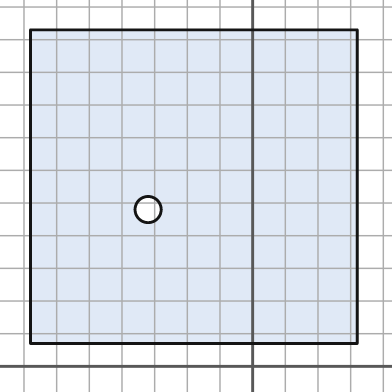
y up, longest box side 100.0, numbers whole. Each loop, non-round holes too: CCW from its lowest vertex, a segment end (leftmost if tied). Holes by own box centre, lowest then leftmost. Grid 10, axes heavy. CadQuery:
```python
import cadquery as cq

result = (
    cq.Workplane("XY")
    .moveTo(-68.0, 7.0)
    .lineTo(32.0, 7.0)
    .lineTo(32.0, 103.0)
    .lineTo(-68.0, 103.0)
    .close()
    .moveTo(-32.0, 48.0)
    .circle(4.0)
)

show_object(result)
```